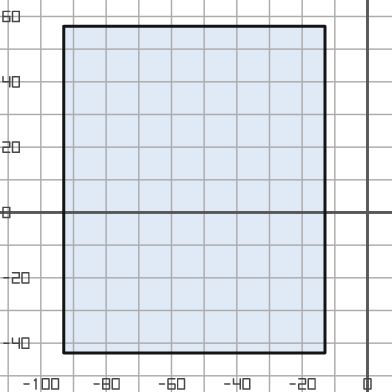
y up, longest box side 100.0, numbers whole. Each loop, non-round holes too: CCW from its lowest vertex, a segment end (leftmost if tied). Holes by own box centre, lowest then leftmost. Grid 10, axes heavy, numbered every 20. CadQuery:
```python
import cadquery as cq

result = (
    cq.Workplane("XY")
    .moveTo(-93.0, -43.0)
    .lineTo(-13.0, -43.0)
    .lineTo(-13.0, 57.0)
    .lineTo(-93.0, 57.0)
    .close()
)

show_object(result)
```